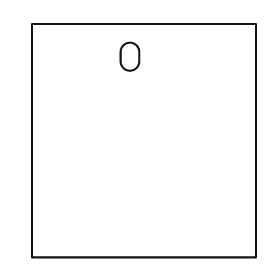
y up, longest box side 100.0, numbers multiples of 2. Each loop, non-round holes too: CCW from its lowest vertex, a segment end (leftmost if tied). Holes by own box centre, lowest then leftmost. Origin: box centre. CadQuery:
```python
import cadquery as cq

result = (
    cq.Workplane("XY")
    .moveTo(-48.0, -50.0)
    .lineTo(48.0, -50.0)
    .lineTo(48.0, 50.0)
    .lineTo(-48.0, 50.0)
    .close()
    .moveTo(-10.0, 34.0)
    .threePointArc((-6.0, 30.0), (-2.0, 34.0))
    .lineTo(-2.0, 38.0)
    .threePointArc((-6.0, 42.0), (-10.0, 38.0))
    .close()
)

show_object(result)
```